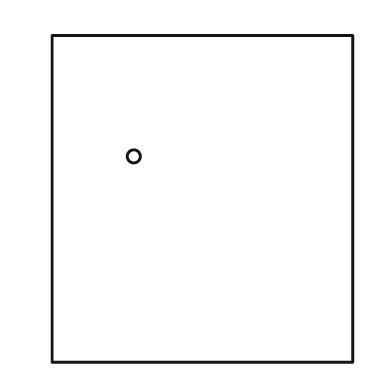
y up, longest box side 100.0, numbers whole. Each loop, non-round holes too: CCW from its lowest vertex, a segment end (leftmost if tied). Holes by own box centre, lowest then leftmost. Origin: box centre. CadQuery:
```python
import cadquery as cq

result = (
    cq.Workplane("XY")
    .moveTo(-46.0, -50.0)
    .lineTo(46.0, -50.0)
    .lineTo(46.0, 50.0)
    .lineTo(-46.0, 50.0)
    .close()
    .moveTo(-21.0, 13.0)
    .circle(2.0)
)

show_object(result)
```